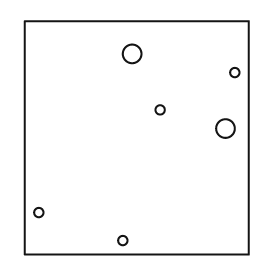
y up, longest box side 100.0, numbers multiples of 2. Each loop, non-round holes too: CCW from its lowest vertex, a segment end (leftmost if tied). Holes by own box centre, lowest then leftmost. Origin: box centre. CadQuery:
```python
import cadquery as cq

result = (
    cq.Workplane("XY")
    .moveTo(-48.0, -50.0)
    .lineTo(48.0, -50.0)
    .lineTo(48.0, 50.0)
    .lineTo(-48.0, 50.0)
    .close()
    .moveTo(-6.0, -44.0)
    .circle(2.0)
    .moveTo(-42.0, -32.0)
    .circle(2.0)
    .moveTo(38.0, 4.0)
    .circle(4.0)
    .moveTo(10.0, 12.0)
    .circle(2.0)
    .moveTo(42.0, 28.0)
    .circle(2.0)
    .moveTo(-2.0, 36.0)
    .circle(4.0)
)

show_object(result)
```